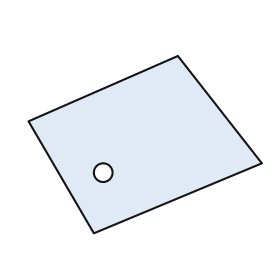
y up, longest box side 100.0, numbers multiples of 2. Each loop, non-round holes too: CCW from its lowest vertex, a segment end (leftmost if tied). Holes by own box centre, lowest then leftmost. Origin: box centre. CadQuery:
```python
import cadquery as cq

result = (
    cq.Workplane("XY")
    .moveTo(-22.0, -38.0)
    .lineTo(50.0, -8.0)
    .lineTo(14.0, 38.0)
    .lineTo(-50.0, 10.0)
    .close()
    .moveTo(-18.0, -12.0)
    .circle(4.0)
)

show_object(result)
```